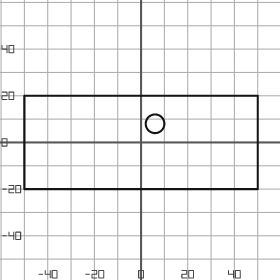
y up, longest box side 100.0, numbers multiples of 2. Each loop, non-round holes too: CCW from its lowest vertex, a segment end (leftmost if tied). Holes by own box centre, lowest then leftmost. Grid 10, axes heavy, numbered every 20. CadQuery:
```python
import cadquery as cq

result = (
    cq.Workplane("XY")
    .moveTo(-50.0, -20.0)
    .lineTo(50.0, -20.0)
    .lineTo(50.0, 20.0)
    .lineTo(-50.0, 20.0)
    .close()
    .moveTo(6.0, 8.0)
    .circle(4.0)
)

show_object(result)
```